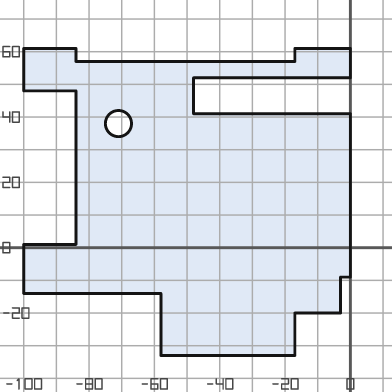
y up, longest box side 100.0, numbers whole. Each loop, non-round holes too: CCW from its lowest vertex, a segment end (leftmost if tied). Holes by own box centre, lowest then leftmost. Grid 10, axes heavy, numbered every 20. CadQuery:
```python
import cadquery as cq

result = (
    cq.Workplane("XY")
    .moveTo(-58.0, -33.0)
    .lineTo(-17.0, -33.0)
    .lineTo(-17.0, -20.0)
    .lineTo(-3.0, -20.0)
    .lineTo(-3.0, -9.0)
    .lineTo(0.0, -9.0)
    .lineTo(0.0, 41.0)
    .lineTo(-48.0, 41.0)
    .lineTo(-48.0, 52.0)
    .lineTo(0.0, 52.0)
    .lineTo(0.0, 61.0)
    .lineTo(-17.0, 61.0)
    .lineTo(-17.0, 57.0)
    .lineTo(-84.0, 57.0)
    .lineTo(-84.0, 61.0)
    .lineTo(-100.0, 61.0)
    .lineTo(-100.0, 48.0)
    .lineTo(-84.0, 48.0)
    .lineTo(-84.0, 1.0)
    .lineTo(-100.0, 1.0)
    .lineTo(-100.0, -14.0)
    .lineTo(-58.0, -14.0)
    .close()
    .moveTo(-71.0, 38.0)
    .circle(4.0)
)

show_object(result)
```